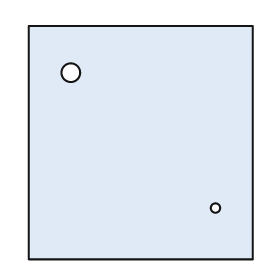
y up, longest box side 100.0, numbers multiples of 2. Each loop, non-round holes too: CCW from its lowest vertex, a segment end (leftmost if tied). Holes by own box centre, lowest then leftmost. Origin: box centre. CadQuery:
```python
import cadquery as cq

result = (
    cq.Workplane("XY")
    .moveTo(-48.0, -50.0)
    .lineTo(48.0, -50.0)
    .lineTo(48.0, 50.0)
    .lineTo(-48.0, 50.0)
    .close()
    .moveTo(32.0, -28.0)
    .circle(2.0)
    .moveTo(-30.0, 30.0)
    .circle(4.0)
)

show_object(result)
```